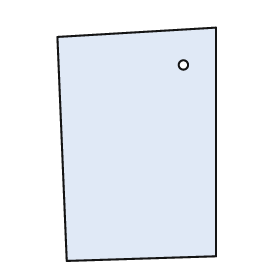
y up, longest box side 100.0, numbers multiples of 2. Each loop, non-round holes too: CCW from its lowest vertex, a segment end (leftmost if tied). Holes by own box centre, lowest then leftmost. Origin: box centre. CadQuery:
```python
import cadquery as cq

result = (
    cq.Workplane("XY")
    .moveTo(-30.0, -50.0)
    .lineTo(34.0, -48.0)
    .lineTo(34.0, 50.0)
    .lineTo(-34.0, 46.0)
    .close()
    .moveTo(20.0, 34.0)
    .circle(2.0)
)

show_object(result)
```